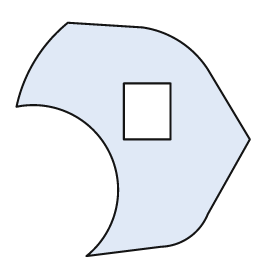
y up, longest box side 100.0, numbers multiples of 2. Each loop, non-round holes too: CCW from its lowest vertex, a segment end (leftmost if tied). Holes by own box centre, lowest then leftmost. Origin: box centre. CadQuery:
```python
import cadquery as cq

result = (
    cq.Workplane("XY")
    .moveTo(-20.0, -50.0)
    .lineTo(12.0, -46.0)
    .threePointArc((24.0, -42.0), (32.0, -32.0))
    .lineTo(50.0, 0.0)
    .lineTo(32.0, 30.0)
    .threePointArc((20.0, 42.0), (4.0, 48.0))
    .lineTo(-28.0, 50.0)
    .threePointArc((-42.0, 34.0), (-50.0, 14.0))
    .threePointArc((-10.0, -6.0), (-20.0, -50.0))
    .close()
    .moveTo(-4.0, 0.0)
    .lineTo(16.0, 0.0)
    .lineTo(16.0, 24.0)
    .lineTo(-4.0, 24.0)
    .close()
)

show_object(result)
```